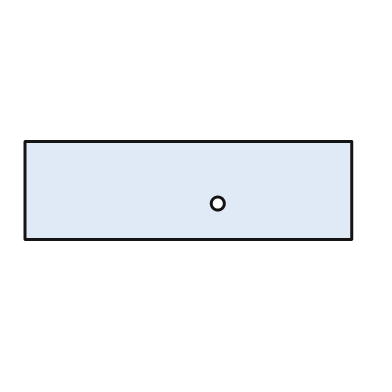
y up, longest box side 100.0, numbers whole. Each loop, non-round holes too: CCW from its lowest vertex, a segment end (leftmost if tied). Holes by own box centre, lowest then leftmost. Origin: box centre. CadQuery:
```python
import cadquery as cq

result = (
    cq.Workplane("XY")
    .moveTo(-50.0, -15.0)
    .lineTo(50.0, -15.0)
    .lineTo(50.0, 15.0)
    .lineTo(-50.0, 15.0)
    .close()
    .moveTo(9.0, -4.0)
    .circle(2.0)
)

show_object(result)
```